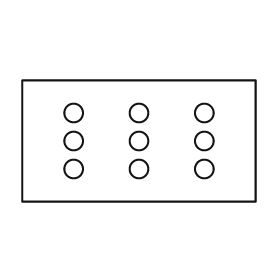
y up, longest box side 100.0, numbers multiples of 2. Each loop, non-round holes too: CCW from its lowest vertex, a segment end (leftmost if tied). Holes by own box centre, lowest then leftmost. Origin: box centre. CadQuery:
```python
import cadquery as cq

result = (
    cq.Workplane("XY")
    .moveTo(-50.0, -26.0)
    .lineTo(50.0, -26.0)
    .lineTo(50.0, 26.0)
    .lineTo(-50.0, 26.0)
    .close()
    .moveTo(-28.0, -12.0)
    .circle(4.0)
    .moveTo(0.0, -12.0)
    .circle(4.0)
    .moveTo(28.0, -12.0)
    .circle(4.0)
    .moveTo(-28.0, 0.0)
    .circle(4.0)
    .moveTo(0.0, 0.0)
    .circle(4.0)
    .moveTo(28.0, 0.0)
    .circle(4.0)
    .moveTo(-28.0, 12.0)
    .circle(4.0)
    .moveTo(0.0, 12.0)
    .circle(4.0)
    .moveTo(28.0, 12.0)
    .circle(4.0)
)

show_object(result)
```